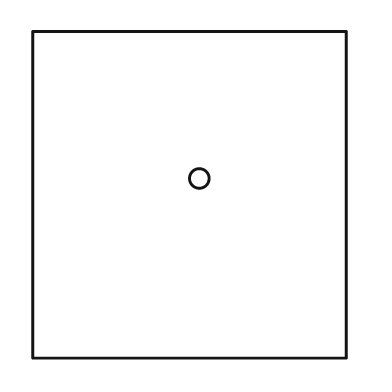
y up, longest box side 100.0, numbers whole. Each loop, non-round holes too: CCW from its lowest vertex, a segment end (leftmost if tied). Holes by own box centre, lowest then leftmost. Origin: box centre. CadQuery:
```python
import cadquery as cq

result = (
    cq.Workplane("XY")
    .moveTo(-48.0, -50.0)
    .lineTo(48.0, -50.0)
    .lineTo(48.0, 50.0)
    .lineTo(-48.0, 50.0)
    .close()
    .moveTo(3.0, 5.0)
    .circle(3.0)
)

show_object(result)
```